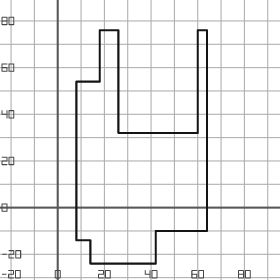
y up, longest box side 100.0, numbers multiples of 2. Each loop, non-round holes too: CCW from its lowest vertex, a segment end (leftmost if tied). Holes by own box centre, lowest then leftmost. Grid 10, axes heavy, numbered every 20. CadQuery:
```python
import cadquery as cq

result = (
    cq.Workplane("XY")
    .moveTo(14.0, -24.0)
    .lineTo(42.0, -24.0)
    .lineTo(42.0, -10.0)
    .lineTo(64.0, -10.0)
    .lineTo(64.0, 76.0)
    .lineTo(60.0, 76.0)
    .lineTo(60.0, 32.0)
    .lineTo(26.0, 32.0)
    .lineTo(26.0, 76.0)
    .lineTo(18.0, 76.0)
    .lineTo(18.0, 54.0)
    .lineTo(8.0, 54.0)
    .lineTo(8.0, -14.0)
    .lineTo(14.0, -14.0)
    .close()
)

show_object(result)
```